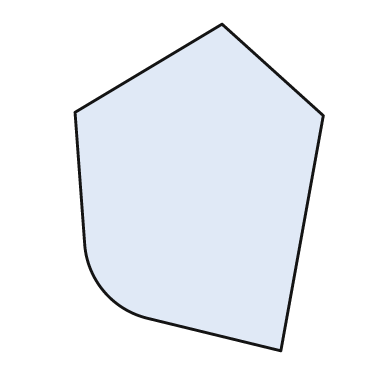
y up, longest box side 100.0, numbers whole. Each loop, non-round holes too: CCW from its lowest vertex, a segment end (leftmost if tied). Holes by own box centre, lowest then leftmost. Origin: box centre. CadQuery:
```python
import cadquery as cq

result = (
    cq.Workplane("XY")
    .moveTo(25.0, -50.0)
    .lineTo(38.0, 22.0)
    .lineTo(7.0, 50.0)
    .lineTo(-38.0, 23.0)
    .lineTo(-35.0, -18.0)
    .threePointArc((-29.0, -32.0), (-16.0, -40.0))
    .close()
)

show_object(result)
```